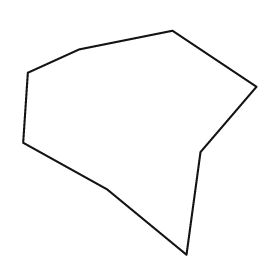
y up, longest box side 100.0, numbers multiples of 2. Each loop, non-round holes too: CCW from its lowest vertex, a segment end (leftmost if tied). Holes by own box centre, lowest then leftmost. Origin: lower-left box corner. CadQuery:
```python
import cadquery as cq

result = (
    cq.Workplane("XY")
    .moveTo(70.0, 0.0)
    .lineTo(76.0, 44.0)
    .lineTo(100.0, 72.0)
    .lineTo(64.0, 96.0)
    .lineTo(24.0, 88.0)
    .lineTo(2.0, 78.0)
    .lineTo(0.0, 48.0)
    .lineTo(36.0, 28.0)
    .close()
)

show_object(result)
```